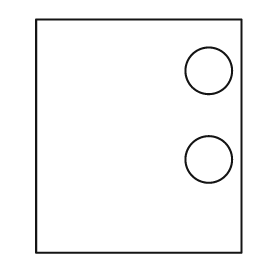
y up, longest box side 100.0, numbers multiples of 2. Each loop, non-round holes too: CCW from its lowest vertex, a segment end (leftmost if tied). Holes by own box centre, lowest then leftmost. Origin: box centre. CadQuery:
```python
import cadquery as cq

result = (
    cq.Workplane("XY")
    .moveTo(-44.0, -50.0)
    .lineTo(44.0, -50.0)
    .lineTo(44.0, 50.0)
    .lineTo(-44.0, 50.0)
    .close()
    .moveTo(30.0, -10.0)
    .circle(10.0)
    .moveTo(30.0, 28.0)
    .circle(10.0)
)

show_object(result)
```